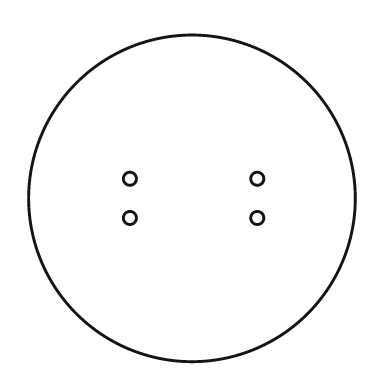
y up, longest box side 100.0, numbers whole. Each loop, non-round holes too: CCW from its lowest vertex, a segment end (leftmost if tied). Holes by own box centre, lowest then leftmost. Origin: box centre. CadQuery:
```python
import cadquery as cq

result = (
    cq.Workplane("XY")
    .moveTo(0.0, 0.0)
    .circle(50.0)
    .moveTo(-19.0, -6.0)
    .circle(2.0)
    .moveTo(20.0, -6.0)
    .circle(2.0)
    .moveTo(-19.0, 6.0)
    .circle(2.0)
    .moveTo(20.0, 6.0)
    .circle(2.0)
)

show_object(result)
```